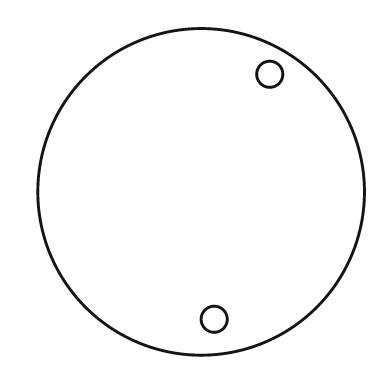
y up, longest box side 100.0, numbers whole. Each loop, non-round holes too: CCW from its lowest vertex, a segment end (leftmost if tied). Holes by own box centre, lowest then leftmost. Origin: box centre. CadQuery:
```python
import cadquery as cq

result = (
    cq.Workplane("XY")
    .moveTo(0.0, 0.0)
    .circle(50.0)
    .moveTo(4.0, -39.0)
    .circle(4.0)
    .moveTo(21.0, 36.0)
    .circle(4.0)
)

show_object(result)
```